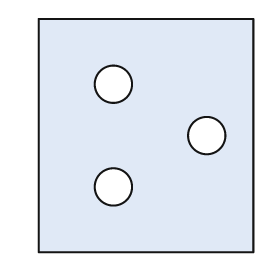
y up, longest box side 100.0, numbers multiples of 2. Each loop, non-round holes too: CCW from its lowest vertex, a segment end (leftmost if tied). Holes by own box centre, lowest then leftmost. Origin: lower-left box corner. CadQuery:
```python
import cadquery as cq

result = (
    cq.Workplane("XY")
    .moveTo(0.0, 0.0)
    .lineTo(92.0, 0.0)
    .lineTo(92.0, 100.0)
    .lineTo(0.0, 100.0)
    .close()
    .moveTo(32.0, 28.0)
    .circle(8.0)
    .moveTo(72.0, 50.0)
    .circle(8.0)
    .moveTo(32.0, 72.0)
    .circle(8.0)
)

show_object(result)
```